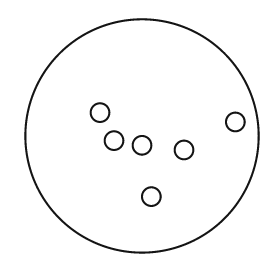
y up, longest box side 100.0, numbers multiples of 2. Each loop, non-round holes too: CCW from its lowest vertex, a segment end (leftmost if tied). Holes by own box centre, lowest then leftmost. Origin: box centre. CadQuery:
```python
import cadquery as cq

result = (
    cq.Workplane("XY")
    .moveTo(0.0, 0.0)
    .circle(50.0)
    .moveTo(4.0, -26.0)
    .circle(4.0)
    .moveTo(18.0, -6.0)
    .circle(4.0)
    .moveTo(0.0, -4.0)
    .circle(4.0)
    .moveTo(-12.0, -2.0)
    .circle(4.0)
    .moveTo(40.0, 6.0)
    .circle(4.0)
    .moveTo(-18.0, 10.0)
    .circle(4.0)
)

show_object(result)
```